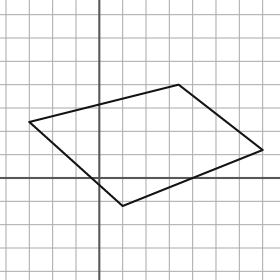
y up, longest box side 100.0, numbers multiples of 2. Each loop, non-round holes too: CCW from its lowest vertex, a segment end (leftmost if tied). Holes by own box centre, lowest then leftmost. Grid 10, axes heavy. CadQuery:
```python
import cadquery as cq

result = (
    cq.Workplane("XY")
    .moveTo(10.0, -12.0)
    .lineTo(70.0, 12.0)
    .lineTo(34.0, 40.0)
    .lineTo(-30.0, 24.0)
    .close()
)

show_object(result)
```